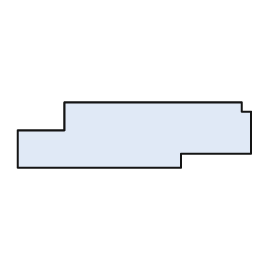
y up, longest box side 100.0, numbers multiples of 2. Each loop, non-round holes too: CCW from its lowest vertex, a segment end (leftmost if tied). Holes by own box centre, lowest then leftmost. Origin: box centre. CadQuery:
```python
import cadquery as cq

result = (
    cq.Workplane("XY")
    .moveTo(-50.0, -14.0)
    .lineTo(20.0, -14.0)
    .lineTo(20.0, -8.0)
    .lineTo(50.0, -8.0)
    .lineTo(50.0, 10.0)
    .lineTo(46.0, 10.0)
    .lineTo(46.0, 14.0)
    .lineTo(-30.0, 14.0)
    .lineTo(-30.0, 2.0)
    .lineTo(-50.0, 2.0)
    .close()
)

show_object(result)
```